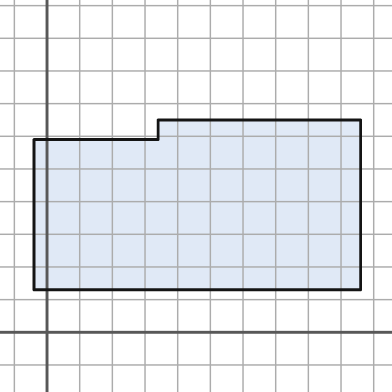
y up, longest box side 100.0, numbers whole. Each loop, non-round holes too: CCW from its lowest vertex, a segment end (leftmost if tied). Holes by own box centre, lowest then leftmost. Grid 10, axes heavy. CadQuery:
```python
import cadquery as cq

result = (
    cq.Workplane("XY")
    .moveTo(-4.0, 13.0)
    .lineTo(96.0, 13.0)
    .lineTo(96.0, 65.0)
    .lineTo(34.0, 65.0)
    .lineTo(34.0, 59.0)
    .lineTo(-4.0, 59.0)
    .close()
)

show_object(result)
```